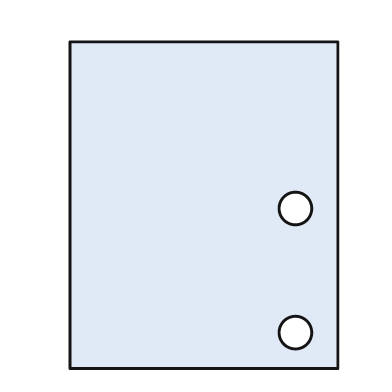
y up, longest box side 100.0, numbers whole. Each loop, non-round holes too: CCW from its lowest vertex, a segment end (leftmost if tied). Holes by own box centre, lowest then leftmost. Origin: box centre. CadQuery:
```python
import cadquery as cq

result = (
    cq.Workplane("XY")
    .moveTo(-41.0, -50.0)
    .lineTo(41.0, -50.0)
    .lineTo(41.0, 50.0)
    .lineTo(-41.0, 50.0)
    .close()
    .moveTo(28.0, -39.0)
    .circle(5.0)
    .moveTo(28.0, -1.0)
    .circle(5.0)
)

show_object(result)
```